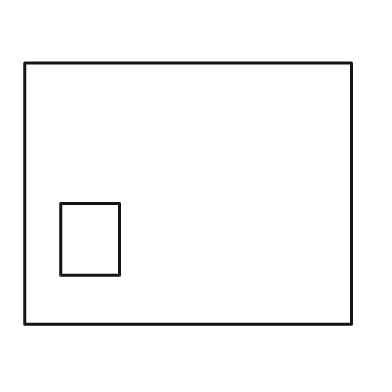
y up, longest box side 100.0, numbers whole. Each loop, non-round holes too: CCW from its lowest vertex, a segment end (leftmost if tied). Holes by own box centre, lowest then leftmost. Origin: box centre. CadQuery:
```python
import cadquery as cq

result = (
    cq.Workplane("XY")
    .moveTo(-50.0, -40.0)
    .lineTo(50.0, -40.0)
    .lineTo(50.0, 40.0)
    .lineTo(-50.0, 40.0)
    .close()
    .moveTo(-39.0, -25.0)
    .lineTo(-21.0, -25.0)
    .lineTo(-21.0, -3.0)
    .lineTo(-39.0, -3.0)
    .close()
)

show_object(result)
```